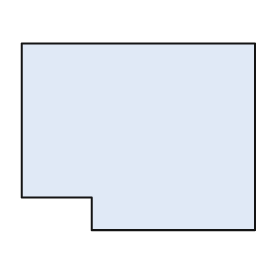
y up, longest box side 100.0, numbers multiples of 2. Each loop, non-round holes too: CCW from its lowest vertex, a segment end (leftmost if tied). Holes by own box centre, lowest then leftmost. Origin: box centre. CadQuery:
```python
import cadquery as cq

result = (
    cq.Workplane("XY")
    .moveTo(-20.0, -40.0)
    .lineTo(50.0, -40.0)
    .lineTo(50.0, 40.0)
    .lineTo(-50.0, 40.0)
    .lineTo(-50.0, -26.0)
    .lineTo(-20.0, -26.0)
    .close()
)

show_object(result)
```